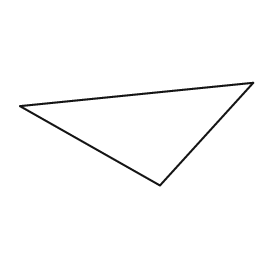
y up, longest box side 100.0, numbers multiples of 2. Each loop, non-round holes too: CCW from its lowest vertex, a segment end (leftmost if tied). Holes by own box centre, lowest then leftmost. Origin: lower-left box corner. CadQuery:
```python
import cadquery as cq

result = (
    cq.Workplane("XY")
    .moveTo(60.0, 0.0)
    .lineTo(100.0, 44.0)
    .lineTo(0.0, 34.0)
    .close()
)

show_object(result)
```